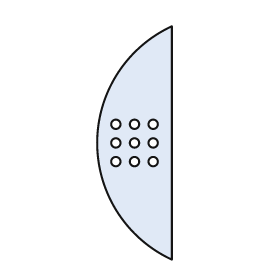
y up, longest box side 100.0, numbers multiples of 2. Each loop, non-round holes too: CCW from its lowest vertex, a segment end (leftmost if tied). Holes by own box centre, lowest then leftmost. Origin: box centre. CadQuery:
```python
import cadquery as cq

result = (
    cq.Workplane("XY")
    .moveTo(16.0, -50.0)
    .lineTo(16.0, 50.0)
    .threePointArc((-16.0, 0.0), (16.0, -50.0))
    .close()
    .moveTo(-8.0, -8.0)
    .circle(2.0)
    .moveTo(0.0, -8.0)
    .circle(2.0)
    .moveTo(8.0, -8.0)
    .circle(2.0)
    .moveTo(-8.0, 0.0)
    .circle(2.0)
    .moveTo(0.0, 0.0)
    .circle(2.0)
    .moveTo(8.0, 0.0)
    .circle(2.0)
    .moveTo(-8.0, 8.0)
    .circle(2.0)
    .moveTo(0.0, 8.0)
    .circle(2.0)
    .moveTo(8.0, 8.0)
    .circle(2.0)
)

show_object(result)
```